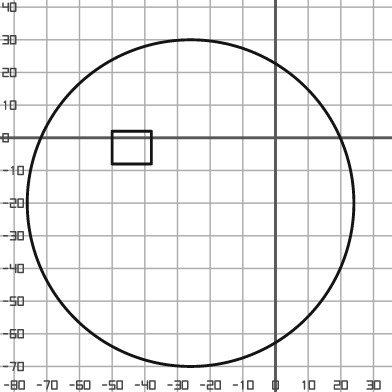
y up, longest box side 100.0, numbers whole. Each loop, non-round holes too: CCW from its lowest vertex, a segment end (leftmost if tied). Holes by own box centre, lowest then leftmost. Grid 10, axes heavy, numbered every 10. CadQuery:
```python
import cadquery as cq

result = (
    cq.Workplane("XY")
    .moveTo(-26.0, -20.0)
    .circle(50.0)
    .moveTo(-50.0, -8.0)
    .lineTo(-38.0, -8.0)
    .lineTo(-38.0, 2.0)
    .lineTo(-50.0, 2.0)
    .close()
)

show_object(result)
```